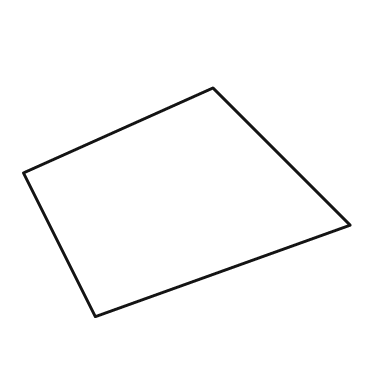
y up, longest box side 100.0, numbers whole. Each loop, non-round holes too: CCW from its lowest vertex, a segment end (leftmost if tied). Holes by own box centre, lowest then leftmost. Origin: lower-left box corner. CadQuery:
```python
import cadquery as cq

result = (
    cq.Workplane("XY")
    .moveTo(22.0, 0.0)
    .lineTo(100.0, 28.0)
    .lineTo(58.0, 70.0)
    .lineTo(0.0, 44.0)
    .close()
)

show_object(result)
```